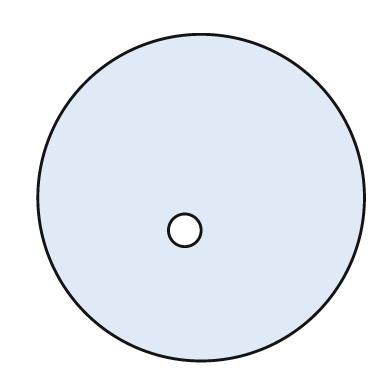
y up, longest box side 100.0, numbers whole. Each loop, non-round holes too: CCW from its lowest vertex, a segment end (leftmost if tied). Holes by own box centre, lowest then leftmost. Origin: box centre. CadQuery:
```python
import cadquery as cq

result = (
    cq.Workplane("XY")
    .moveTo(0.0, 0.0)
    .circle(50.0)
    .moveTo(-5.0, -10.0)
    .circle(5.0)
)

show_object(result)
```